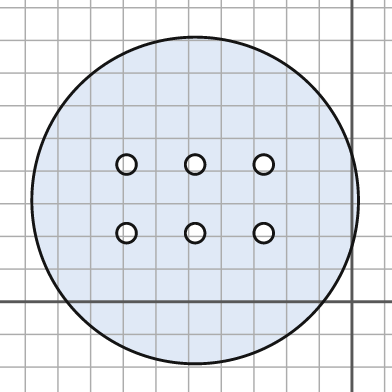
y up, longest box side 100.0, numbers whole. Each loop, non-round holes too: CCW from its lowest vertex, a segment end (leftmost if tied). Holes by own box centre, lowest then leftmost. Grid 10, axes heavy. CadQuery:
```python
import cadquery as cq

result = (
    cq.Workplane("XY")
    .moveTo(-48.0, 31.0)
    .circle(50.0)
    .moveTo(-69.0, 21.0)
    .circle(3.0)
    .moveTo(-48.0, 21.0)
    .circle(3.0)
    .moveTo(-27.0, 21.0)
    .circle(3.0)
    .moveTo(-69.0, 42.0)
    .circle(3.0)
    .moveTo(-48.0, 42.0)
    .circle(3.0)
    .moveTo(-27.0, 42.0)
    .circle(3.0)
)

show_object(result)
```